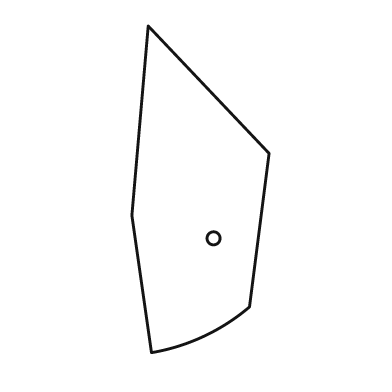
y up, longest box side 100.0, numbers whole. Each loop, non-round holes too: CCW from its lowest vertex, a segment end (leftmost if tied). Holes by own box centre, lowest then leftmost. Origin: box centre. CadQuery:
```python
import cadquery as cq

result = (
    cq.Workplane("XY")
    .moveTo(-15.0, -50.0)
    .threePointArc((1.0, -45.0), (15.0, -36.0))
    .lineTo(21.0, 11.0)
    .lineTo(-16.0, 50.0)
    .lineTo(-21.0, -8.0)
    .close()
    .moveTo(4.0, -15.0)
    .circle(2.0)
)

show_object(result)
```